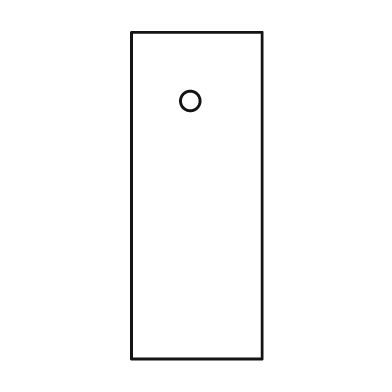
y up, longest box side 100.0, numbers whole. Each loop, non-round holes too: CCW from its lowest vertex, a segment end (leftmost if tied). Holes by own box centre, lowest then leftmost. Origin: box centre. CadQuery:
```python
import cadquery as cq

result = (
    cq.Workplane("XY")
    .moveTo(-20.0, -50.0)
    .lineTo(20.0, -50.0)
    .lineTo(20.0, 50.0)
    .lineTo(-20.0, 50.0)
    .close()
    .moveTo(-2.0, 29.0)
    .circle(3.0)
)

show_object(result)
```